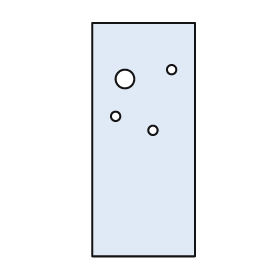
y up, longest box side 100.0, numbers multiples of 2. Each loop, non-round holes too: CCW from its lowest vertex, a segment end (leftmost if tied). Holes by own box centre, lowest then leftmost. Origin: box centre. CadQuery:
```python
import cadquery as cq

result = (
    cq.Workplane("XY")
    .moveTo(-22.0, -50.0)
    .lineTo(22.0, -50.0)
    .lineTo(22.0, 50.0)
    .lineTo(-22.0, 50.0)
    .close()
    .moveTo(4.0, 4.0)
    .circle(2.0)
    .moveTo(-12.0, 10.0)
    .circle(2.0)
    .moveTo(-8.0, 26.0)
    .circle(4.0)
    .moveTo(12.0, 30.0)
    .circle(2.0)
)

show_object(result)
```